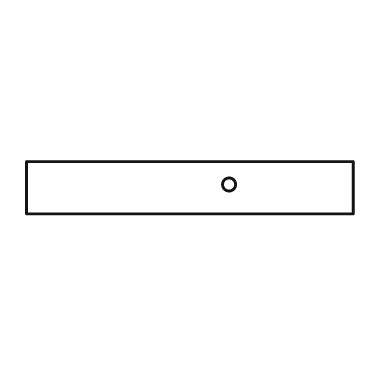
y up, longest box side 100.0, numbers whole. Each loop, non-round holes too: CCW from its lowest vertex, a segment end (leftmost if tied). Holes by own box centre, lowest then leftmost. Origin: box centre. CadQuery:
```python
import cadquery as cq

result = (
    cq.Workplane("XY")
    .moveTo(-50.0, -8.0)
    .lineTo(50.0, -8.0)
    .lineTo(50.0, 8.0)
    .lineTo(-50.0, 8.0)
    .close()
    .moveTo(12.0, 1.0)
    .circle(2.0)
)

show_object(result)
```